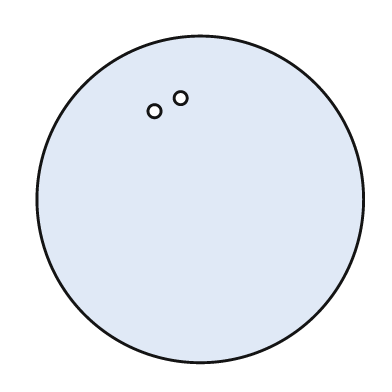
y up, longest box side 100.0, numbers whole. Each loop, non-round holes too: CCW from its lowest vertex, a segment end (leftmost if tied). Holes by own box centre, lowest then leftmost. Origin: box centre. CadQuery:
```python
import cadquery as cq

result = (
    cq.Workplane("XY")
    .moveTo(0.0, 0.0)
    .circle(50.0)
    .moveTo(-14.0, 27.0)
    .circle(2.0)
    .moveTo(-6.0, 31.0)
    .circle(2.0)
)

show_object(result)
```